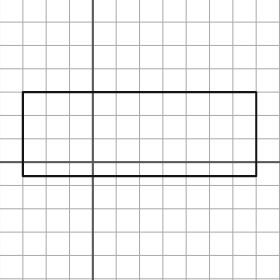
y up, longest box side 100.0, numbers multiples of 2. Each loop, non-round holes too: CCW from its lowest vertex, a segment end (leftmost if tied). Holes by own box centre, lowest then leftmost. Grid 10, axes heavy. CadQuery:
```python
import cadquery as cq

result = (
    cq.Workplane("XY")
    .moveTo(-30.0, -6.0)
    .lineTo(70.0, -6.0)
    .lineTo(70.0, 30.0)
    .lineTo(-30.0, 30.0)
    .close()
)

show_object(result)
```